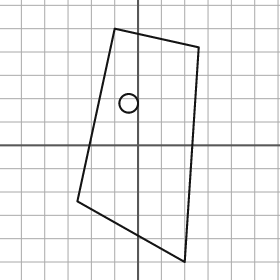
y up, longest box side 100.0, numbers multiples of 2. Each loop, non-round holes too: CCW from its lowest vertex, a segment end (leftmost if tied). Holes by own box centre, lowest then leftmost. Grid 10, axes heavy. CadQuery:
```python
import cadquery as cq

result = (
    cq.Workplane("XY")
    .moveTo(20.0, -50.0)
    .lineTo(26.0, 42.0)
    .lineTo(-10.0, 50.0)
    .lineTo(-26.0, -24.0)
    .close()
    .moveTo(-4.0, 18.0)
    .circle(4.0)
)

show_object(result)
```